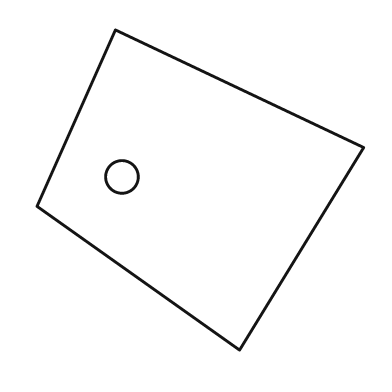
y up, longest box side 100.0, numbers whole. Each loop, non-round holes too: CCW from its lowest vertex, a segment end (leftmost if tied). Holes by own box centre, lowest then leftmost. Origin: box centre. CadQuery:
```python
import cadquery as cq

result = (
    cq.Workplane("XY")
    .moveTo(12.0, -49.0)
    .lineTo(50.0, 13.0)
    .lineTo(-26.0, 49.0)
    .lineTo(-50.0, -5.0)
    .close()
    .moveTo(-24.0, 4.0)
    .circle(5.0)
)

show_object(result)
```